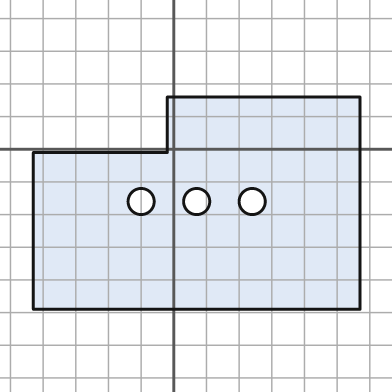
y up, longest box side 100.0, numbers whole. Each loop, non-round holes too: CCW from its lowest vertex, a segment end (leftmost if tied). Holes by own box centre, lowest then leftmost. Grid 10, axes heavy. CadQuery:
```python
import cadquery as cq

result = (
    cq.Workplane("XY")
    .moveTo(-43.0, -49.0)
    .lineTo(57.0, -49.0)
    .lineTo(57.0, 16.0)
    .lineTo(-2.0, 16.0)
    .lineTo(-2.0, -1.0)
    .lineTo(-43.0, -1.0)
    .close()
    .moveTo(-10.0, -16.0)
    .circle(4.0)
    .moveTo(7.0, -16.0)
    .circle(4.0)
    .moveTo(24.0, -16.0)
    .circle(4.0)
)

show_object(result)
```